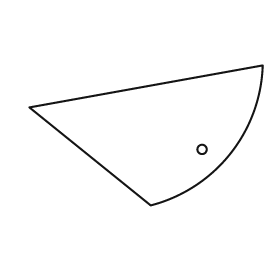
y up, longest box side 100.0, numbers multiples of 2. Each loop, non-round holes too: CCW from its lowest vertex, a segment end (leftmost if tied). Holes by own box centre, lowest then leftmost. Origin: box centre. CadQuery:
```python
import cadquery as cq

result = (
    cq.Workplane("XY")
    .moveTo(2.0, -30.0)
    .threePointArc((36.0, -8.0), (50.0, 30.0))
    .lineTo(-50.0, 12.0)
    .close()
    .moveTo(24.0, -6.0)
    .circle(2.0)
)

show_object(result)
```